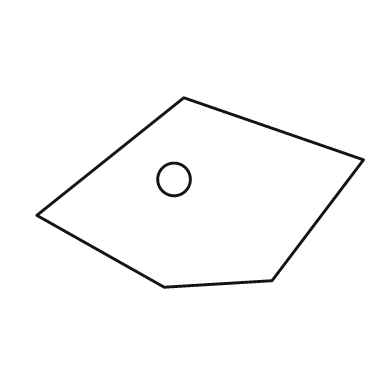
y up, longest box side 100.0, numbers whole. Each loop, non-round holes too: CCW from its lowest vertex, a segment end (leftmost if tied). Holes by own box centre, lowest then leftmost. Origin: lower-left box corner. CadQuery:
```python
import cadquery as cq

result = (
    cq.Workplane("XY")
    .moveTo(39.0, 0.0)
    .lineTo(72.0, 2.0)
    .lineTo(100.0, 39.0)
    .lineTo(45.0, 58.0)
    .lineTo(0.0, 22.0)
    .close()
    .moveTo(42.0, 33.0)
    .circle(5.0)
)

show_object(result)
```